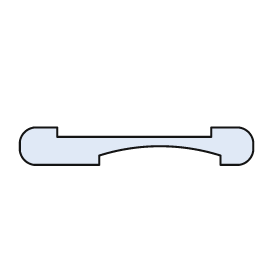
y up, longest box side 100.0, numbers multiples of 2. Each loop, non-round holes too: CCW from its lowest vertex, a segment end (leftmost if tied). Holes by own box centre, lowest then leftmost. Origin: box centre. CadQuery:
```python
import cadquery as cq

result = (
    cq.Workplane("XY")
    .moveTo(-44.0, -8.0)
    .lineTo(-16.0, -8.0)
    .lineTo(-16.0, -4.0)
    .threePointArc((10.0, 0.0), (36.0, -4.0))
    .lineTo(36.0, -8.0)
    .lineTo(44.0, -8.0)
    .threePointArc((48.0, -6.0), (50.0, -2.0))
    .lineTo(50.0, 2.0)
    .threePointArc((48.0, 6.0), (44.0, 8.0))
    .lineTo(32.0, 8.0)
    .lineTo(32.0, 4.0)
    .lineTo(-34.0, 4.0)
    .lineTo(-34.0, 8.0)
    .lineTo(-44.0, 8.0)
    .threePointArc((-48.0, 6.0), (-50.0, 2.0))
    .lineTo(-50.0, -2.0)
    .threePointArc((-48.0, -6.0), (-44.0, -8.0))
    .close()
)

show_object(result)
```